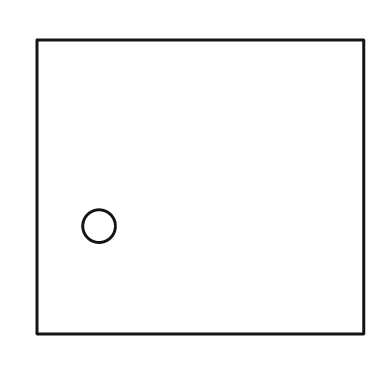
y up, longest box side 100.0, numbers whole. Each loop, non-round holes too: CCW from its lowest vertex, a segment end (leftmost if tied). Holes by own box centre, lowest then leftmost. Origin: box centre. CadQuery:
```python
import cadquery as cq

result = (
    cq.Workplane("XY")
    .moveTo(-50.0, -45.0)
    .lineTo(50.0, -45.0)
    .lineTo(50.0, 45.0)
    .lineTo(-50.0, 45.0)
    .close()
    .moveTo(-31.0, -12.0)
    .circle(5.0)
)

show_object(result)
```